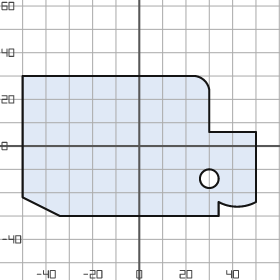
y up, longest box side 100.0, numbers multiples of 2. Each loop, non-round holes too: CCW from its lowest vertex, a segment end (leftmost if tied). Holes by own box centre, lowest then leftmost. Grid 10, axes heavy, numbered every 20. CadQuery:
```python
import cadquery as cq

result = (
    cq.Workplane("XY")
    .moveTo(-34.0, -30.0)
    .lineTo(34.0, -30.0)
    .lineTo(34.0, -24.0)
    .threePointArc((42.0, -26.0), (50.0, -24.0))
    .lineTo(50.0, 6.0)
    .lineTo(30.0, 6.0)
    .lineTo(30.0, 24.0)
    .threePointArc((28.0, 28.0), (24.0, 30.0))
    .lineTo(-50.0, 30.0)
    .lineTo(-50.0, -22.0)
    .close()
    .moveTo(30.0, -14.0)
    .circle(4.0)
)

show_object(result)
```